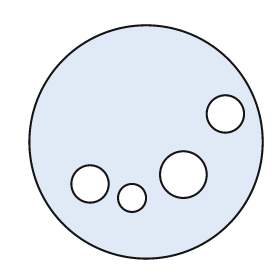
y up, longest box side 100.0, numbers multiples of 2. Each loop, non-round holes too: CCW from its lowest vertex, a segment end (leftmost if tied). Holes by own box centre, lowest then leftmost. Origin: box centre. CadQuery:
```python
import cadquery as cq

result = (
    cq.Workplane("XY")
    .moveTo(0.0, 0.0)
    .circle(50.0)
    .moveTo(-6.0, -24.0)
    .circle(6.0)
    .moveTo(-24.0, -18.0)
    .circle(8.0)
    .moveTo(16.0, -14.0)
    .circle(10.0)
    .moveTo(34.0, 12.0)
    .circle(8.0)
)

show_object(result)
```